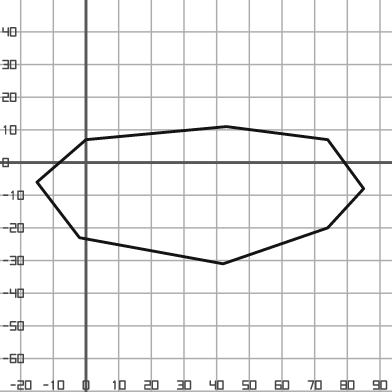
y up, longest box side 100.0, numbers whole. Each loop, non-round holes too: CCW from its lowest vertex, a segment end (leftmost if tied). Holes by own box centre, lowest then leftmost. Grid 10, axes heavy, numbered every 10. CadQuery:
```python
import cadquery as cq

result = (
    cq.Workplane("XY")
    .moveTo(42.0, -31.0)
    .lineTo(74.0, -20.0)
    .lineTo(85.0, -8.0)
    .lineTo(74.0, 7.0)
    .lineTo(43.0, 11.0)
    .lineTo(0.0, 7.0)
    .lineTo(-15.0, -6.0)
    .lineTo(-2.0, -23.0)
    .close()
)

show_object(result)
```